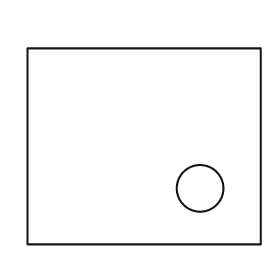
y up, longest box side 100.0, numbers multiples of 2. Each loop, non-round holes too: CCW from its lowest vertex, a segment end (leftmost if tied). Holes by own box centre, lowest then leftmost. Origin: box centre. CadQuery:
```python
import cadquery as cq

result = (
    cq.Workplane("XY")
    .moveTo(-50.0, -42.0)
    .lineTo(50.0, -42.0)
    .lineTo(50.0, 42.0)
    .lineTo(-50.0, 42.0)
    .close()
    .moveTo(24.0, -18.0)
    .circle(10.0)
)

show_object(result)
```